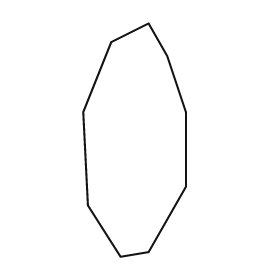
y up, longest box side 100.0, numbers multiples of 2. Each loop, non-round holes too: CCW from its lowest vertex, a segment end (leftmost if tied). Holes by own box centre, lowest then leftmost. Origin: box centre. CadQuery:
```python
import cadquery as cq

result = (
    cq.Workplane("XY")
    .moveTo(-6.0, -50.0)
    .lineTo(6.0, -48.0)
    .lineTo(22.0, -20.0)
    .lineTo(22.0, 12.0)
    .lineTo(14.0, 36.0)
    .lineTo(6.0, 50.0)
    .lineTo(-10.0, 42.0)
    .lineTo(-22.0, 12.0)
    .lineTo(-20.0, -28.0)
    .close()
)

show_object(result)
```